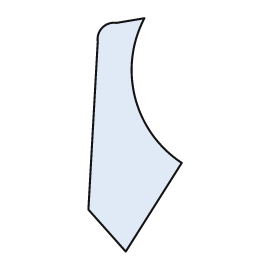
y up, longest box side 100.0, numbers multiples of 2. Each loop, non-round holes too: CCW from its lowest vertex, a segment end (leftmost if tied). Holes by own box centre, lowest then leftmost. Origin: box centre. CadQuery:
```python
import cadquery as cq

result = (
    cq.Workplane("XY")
    .moveTo(-4.0, -50.0)
    .lineTo(20.0, -12.0)
    .threePointArc((0.0, 16.0), (4.0, 50.0))
    .lineTo(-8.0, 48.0)
    .threePointArc((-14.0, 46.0), (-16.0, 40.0))
    .lineTo(-20.0, -32.0)
    .close()
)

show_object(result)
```